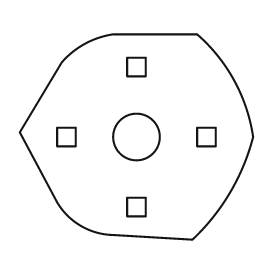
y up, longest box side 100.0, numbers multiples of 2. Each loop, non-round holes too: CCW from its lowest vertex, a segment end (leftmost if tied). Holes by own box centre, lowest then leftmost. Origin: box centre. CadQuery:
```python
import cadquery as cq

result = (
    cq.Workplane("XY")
    .moveTo(24.0, -44.0)
    .threePointArc((40.0, -24.0), (50.0, 0.0))
    .threePointArc((42.0, 24.0), (26.0, 44.0))
    .lineTo(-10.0, 44.0)
    .threePointArc((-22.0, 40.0), (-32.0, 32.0))
    .lineTo(-50.0, 2.0)
    .lineTo(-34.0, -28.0)
    .threePointArc((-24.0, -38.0), (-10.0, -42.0))
    .close()
    .moveTo(-4.0, -34.0)
    .lineTo(4.0, -34.0)
    .lineTo(4.0, -26.0)
    .lineTo(-4.0, -26.0)
    .close()
    .moveTo(-34.0, -4.0)
    .lineTo(-26.0, -4.0)
    .lineTo(-26.0, 4.0)
    .lineTo(-34.0, 4.0)
    .close()
    .moveTo(0.0, 0.0)
    .circle(10.0)
    .moveTo(26.0, -4.0)
    .lineTo(34.0, -4.0)
    .lineTo(34.0, 4.0)
    .lineTo(26.0, 4.0)
    .close()
    .moveTo(-4.0, 26.0)
    .lineTo(4.0, 26.0)
    .lineTo(4.0, 34.0)
    .lineTo(-4.0, 34.0)
    .close()
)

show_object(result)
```